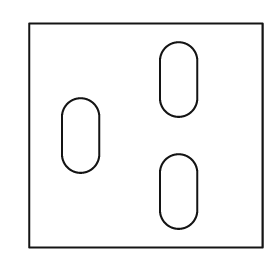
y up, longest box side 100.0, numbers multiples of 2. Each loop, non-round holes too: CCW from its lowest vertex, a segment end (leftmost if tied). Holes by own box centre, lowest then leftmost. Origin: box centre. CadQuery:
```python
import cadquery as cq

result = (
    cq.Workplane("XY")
    .moveTo(-50.0, -48.0)
    .lineTo(50.0, -48.0)
    .lineTo(50.0, 48.0)
    .lineTo(-50.0, 48.0)
    .close()
    .moveTo(6.0, -32.0)
    .threePointArc((14.0, -40.0), (22.0, -32.0))
    .lineTo(22.0, -16.0)
    .threePointArc((14.0, -8.0), (6.0, -16.0))
    .close()
    .moveTo(-36.0, -8.0)
    .threePointArc((-28.0, -16.0), (-20.0, -8.0))
    .lineTo(-20.0, 8.0)
    .threePointArc((-28.0, 16.0), (-36.0, 8.0))
    .close()
    .moveTo(6.0, 16.0)
    .threePointArc((14.0, 8.0), (22.0, 16.0))
    .lineTo(22.0, 32.0)
    .threePointArc((14.0, 40.0), (6.0, 32.0))
    .close()
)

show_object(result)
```